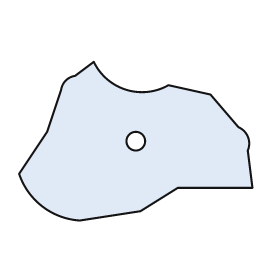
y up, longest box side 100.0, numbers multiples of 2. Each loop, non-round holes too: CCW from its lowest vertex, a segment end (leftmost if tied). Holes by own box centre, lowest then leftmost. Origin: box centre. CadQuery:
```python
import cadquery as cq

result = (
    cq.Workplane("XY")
    .moveTo(-24.0, -34.0)
    .lineTo(2.0, -30.0)
    .lineTo(18.0, -20.0)
    .lineTo(50.0, -20.0)
    .lineTo(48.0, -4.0)
    .threePointArc((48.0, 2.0), (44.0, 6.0))
    .lineTo(32.0, 20.0)
    .lineTo(14.0, 24.0)
    .threePointArc((-4.0, 22.0), (-18.0, 34.0))
    .lineTo(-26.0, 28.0)
    .threePointArc((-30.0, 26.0), (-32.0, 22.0))
    .lineTo(-38.0, 4.0)
    .lineTo(-50.0, -14.0)
    .threePointArc((-40.0, -28.0), (-24.0, -34.0))
    .close()
    .moveTo(0.0, 0.0)
    .circle(4.0)
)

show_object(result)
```